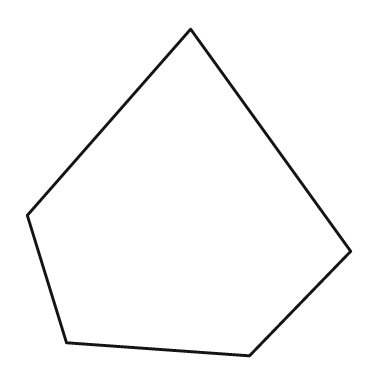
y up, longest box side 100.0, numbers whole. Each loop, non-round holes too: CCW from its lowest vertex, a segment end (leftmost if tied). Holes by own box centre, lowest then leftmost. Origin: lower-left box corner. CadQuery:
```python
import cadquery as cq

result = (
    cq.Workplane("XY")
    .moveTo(68.0, 0.0)
    .lineTo(99.0, 32.0)
    .lineTo(50.0, 100.0)
    .lineTo(0.0, 43.0)
    .lineTo(12.0, 4.0)
    .close()
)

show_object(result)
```